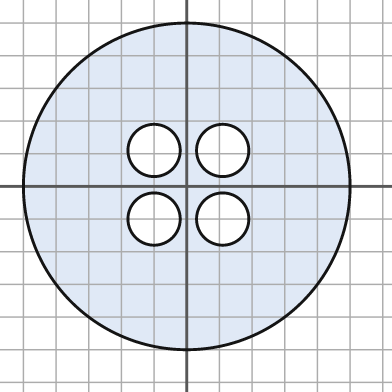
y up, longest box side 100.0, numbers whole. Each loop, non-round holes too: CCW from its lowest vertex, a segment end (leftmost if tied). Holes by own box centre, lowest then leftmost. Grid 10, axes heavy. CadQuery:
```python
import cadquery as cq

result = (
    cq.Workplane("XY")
    .moveTo(0.0, 0.0)
    .circle(50.0)
    .moveTo(-10.0, -10.0)
    .circle(8.0)
    .moveTo(11.0, -10.0)
    .circle(8.0)
    .moveTo(-10.0, 11.0)
    .circle(8.0)
    .moveTo(11.0, 11.0)
    .circle(8.0)
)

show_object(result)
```